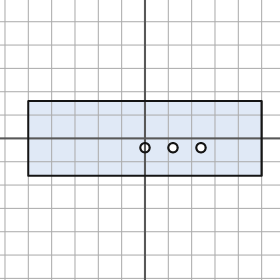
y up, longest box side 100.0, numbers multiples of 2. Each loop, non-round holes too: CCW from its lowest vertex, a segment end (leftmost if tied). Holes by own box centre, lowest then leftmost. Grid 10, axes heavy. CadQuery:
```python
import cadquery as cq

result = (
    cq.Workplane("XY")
    .moveTo(-50.0, -16.0)
    .lineTo(50.0, -16.0)
    .lineTo(50.0, 16.0)
    .lineTo(-50.0, 16.0)
    .close()
    .moveTo(0.0, -4.0)
    .circle(2.0)
    .moveTo(12.0, -4.0)
    .circle(2.0)
    .moveTo(24.0, -4.0)
    .circle(2.0)
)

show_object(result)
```